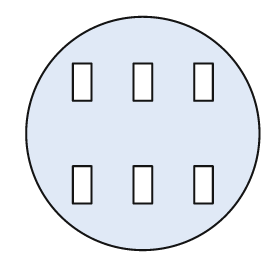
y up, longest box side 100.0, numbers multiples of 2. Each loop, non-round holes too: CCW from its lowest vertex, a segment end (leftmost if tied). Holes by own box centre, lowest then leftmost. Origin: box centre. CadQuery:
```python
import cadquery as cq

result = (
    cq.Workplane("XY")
    .moveTo(0.0, 0.0)
    .circle(50.0)
    .moveTo(-30.0, -30.0)
    .lineTo(-22.0, -30.0)
    .lineTo(-22.0, -14.0)
    .lineTo(-30.0, -14.0)
    .close()
    .moveTo(-4.0, -30.0)
    .lineTo(4.0, -30.0)
    .lineTo(4.0, -14.0)
    .lineTo(-4.0, -14.0)
    .close()
    .moveTo(22.0, -30.0)
    .lineTo(30.0, -30.0)
    .lineTo(30.0, -14.0)
    .lineTo(22.0, -14.0)
    .close()
    .moveTo(-30.0, 14.0)
    .lineTo(-22.0, 14.0)
    .lineTo(-22.0, 30.0)
    .lineTo(-30.0, 30.0)
    .close()
    .moveTo(-4.0, 14.0)
    .lineTo(4.0, 14.0)
    .lineTo(4.0, 30.0)
    .lineTo(-4.0, 30.0)
    .close()
    .moveTo(22.0, 14.0)
    .lineTo(30.0, 14.0)
    .lineTo(30.0, 30.0)
    .lineTo(22.0, 30.0)
    .close()
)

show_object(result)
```